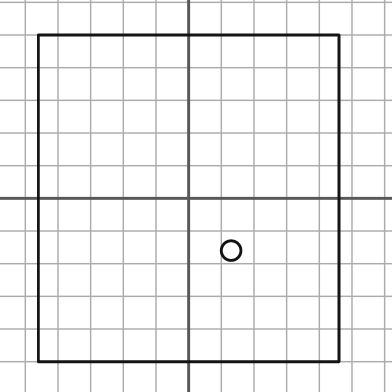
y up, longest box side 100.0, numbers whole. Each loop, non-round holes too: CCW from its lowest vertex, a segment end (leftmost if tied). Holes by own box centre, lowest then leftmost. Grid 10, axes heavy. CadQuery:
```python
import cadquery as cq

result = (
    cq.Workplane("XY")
    .moveTo(-46.0, -50.0)
    .lineTo(46.0, -50.0)
    .lineTo(46.0, 50.0)
    .lineTo(-46.0, 50.0)
    .close()
    .moveTo(13.0, -16.0)
    .circle(3.0)
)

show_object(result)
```